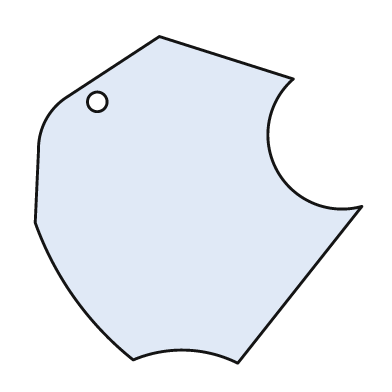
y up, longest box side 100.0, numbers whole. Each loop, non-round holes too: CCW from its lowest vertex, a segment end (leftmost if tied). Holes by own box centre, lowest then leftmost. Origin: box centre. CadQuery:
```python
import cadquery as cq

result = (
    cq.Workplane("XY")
    .moveTo(12.0, -50.0)
    .lineTo(50.0, -2.0)
    .threePointArc((24.0, 9.0), (29.0, 37.0))
    .lineTo(-12.0, 50.0)
    .lineTo(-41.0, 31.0)
    .threePointArc((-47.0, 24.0), (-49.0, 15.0))
    .lineTo(-50.0, -7.0)
    .threePointArc((-38.0, -30.0), (-20.0, -49.0))
    .threePointArc((-4.0, -46.0), (12.0, -50.0))
    .close()
    .moveTo(-31.0, 30.0)
    .circle(3.0)
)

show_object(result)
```